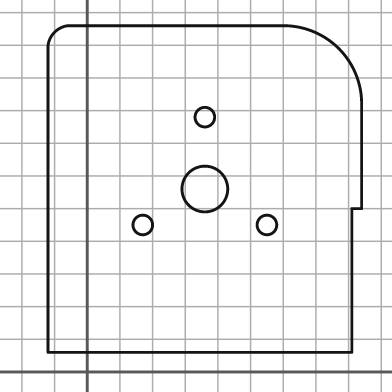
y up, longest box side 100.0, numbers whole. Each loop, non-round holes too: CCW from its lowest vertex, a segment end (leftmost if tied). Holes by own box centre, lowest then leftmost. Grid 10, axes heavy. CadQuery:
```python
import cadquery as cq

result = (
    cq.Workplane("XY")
    .moveTo(-12.0, 6.0)
    .lineTo(81.0, 6.0)
    .lineTo(81.0, 50.0)
    .lineTo(84.0, 50.0)
    .lineTo(84.0, 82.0)
    .threePointArc((77.0, 99.0), (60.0, 106.0))
    .lineTo(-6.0, 106.0)
    .threePointArc((-10.0, 104.0), (-12.0, 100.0))
    .close()
    .moveTo(17.0, 45.0)
    .circle(3.0)
    .moveTo(55.0, 45.0)
    .circle(3.0)
    .moveTo(36.0, 56.0)
    .circle(7.0)
    .moveTo(36.0, 78.0)
    .circle(3.0)
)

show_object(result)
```